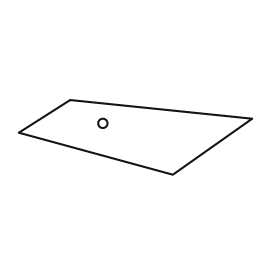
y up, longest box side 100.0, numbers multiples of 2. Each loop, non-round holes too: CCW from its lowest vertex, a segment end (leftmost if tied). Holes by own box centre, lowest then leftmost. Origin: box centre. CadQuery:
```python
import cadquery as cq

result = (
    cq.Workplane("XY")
    .moveTo(16.0, -16.0)
    .lineTo(50.0, 8.0)
    .lineTo(-28.0, 16.0)
    .lineTo(-50.0, 2.0)
    .close()
    .moveTo(-14.0, 6.0)
    .circle(2.0)
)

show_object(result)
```